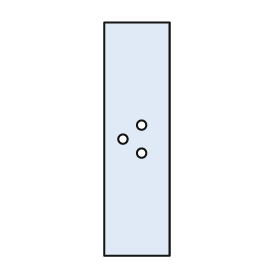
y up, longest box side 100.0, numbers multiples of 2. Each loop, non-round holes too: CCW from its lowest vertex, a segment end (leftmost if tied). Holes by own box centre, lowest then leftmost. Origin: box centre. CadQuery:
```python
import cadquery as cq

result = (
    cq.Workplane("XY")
    .moveTo(-14.0, -50.0)
    .lineTo(14.0, -50.0)
    .lineTo(14.0, 50.0)
    .lineTo(-14.0, 50.0)
    .close()
    .moveTo(2.0, -6.0)
    .circle(2.0)
    .moveTo(-6.0, 0.0)
    .circle(2.0)
    .moveTo(2.0, 6.0)
    .circle(2.0)
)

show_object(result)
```